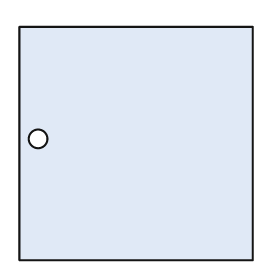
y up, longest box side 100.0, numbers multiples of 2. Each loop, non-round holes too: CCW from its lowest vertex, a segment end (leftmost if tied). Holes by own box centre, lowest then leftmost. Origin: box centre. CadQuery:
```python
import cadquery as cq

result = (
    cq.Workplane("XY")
    .moveTo(-50.0, -50.0)
    .lineTo(50.0, -50.0)
    .lineTo(50.0, 50.0)
    .lineTo(-50.0, 50.0)
    .close()
    .moveTo(-42.0, 2.0)
    .circle(4.0)
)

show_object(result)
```